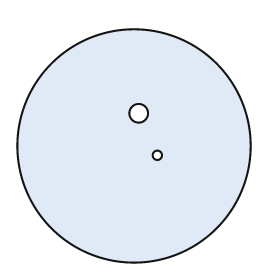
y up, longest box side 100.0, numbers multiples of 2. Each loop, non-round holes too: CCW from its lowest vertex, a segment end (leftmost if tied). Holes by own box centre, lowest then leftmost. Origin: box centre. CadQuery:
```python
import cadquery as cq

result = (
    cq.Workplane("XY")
    .moveTo(0.0, 0.0)
    .circle(50.0)
    .moveTo(10.0, -4.0)
    .circle(2.0)
    .moveTo(2.0, 14.0)
    .circle(4.0)
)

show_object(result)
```